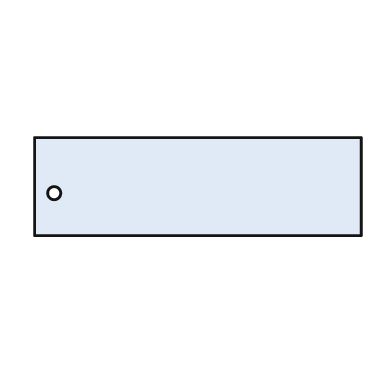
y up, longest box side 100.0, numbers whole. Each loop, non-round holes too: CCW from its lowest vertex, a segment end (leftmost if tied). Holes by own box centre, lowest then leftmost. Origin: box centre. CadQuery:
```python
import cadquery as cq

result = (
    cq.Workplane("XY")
    .moveTo(-50.0, -15.0)
    .lineTo(50.0, -15.0)
    .lineTo(50.0, 15.0)
    .lineTo(-50.0, 15.0)
    .close()
    .moveTo(-44.0, -2.0)
    .circle(2.0)
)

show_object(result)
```